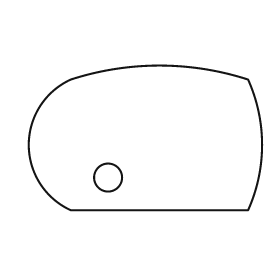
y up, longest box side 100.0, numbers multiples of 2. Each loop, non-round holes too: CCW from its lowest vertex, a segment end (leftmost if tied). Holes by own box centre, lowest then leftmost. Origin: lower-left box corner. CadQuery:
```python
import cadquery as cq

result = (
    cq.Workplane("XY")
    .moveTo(18.0, 0.0)
    .lineTo(94.0, 0.0)
    .threePointArc((100.0, 28.0), (94.0, 56.0))
    .threePointArc((56.0, 62.0), (18.0, 56.0))
    .threePointArc((0.0, 28.0), (18.0, 0.0))
    .close()
    .moveTo(34.0, 14.0)
    .circle(6.0)
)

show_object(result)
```